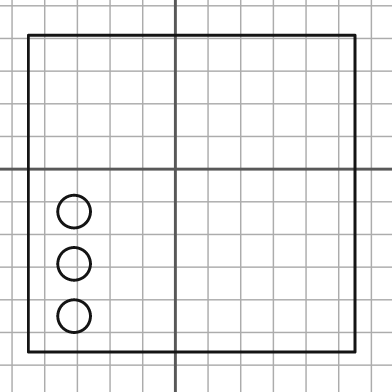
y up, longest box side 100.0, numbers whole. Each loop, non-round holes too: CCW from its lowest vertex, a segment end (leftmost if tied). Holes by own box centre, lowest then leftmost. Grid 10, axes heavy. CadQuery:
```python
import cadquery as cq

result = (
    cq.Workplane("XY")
    .moveTo(-45.0, -56.0)
    .lineTo(55.0, -56.0)
    .lineTo(55.0, 41.0)
    .lineTo(-45.0, 41.0)
    .close()
    .moveTo(-31.0, -45.0)
    .circle(5.0)
    .moveTo(-31.0, -29.0)
    .circle(5.0)
    .moveTo(-31.0, -13.0)
    .circle(5.0)
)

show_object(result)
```